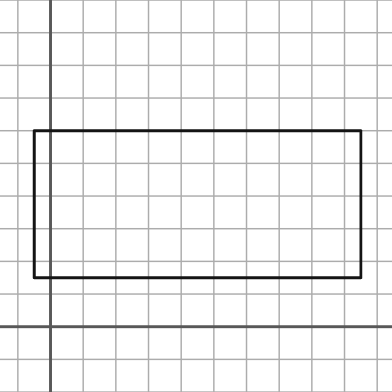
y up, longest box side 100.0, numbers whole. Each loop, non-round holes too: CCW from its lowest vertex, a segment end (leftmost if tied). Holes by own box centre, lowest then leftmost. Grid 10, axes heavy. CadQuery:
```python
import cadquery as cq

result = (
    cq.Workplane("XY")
    .moveTo(-5.0, 15.0)
    .lineTo(95.0, 15.0)
    .lineTo(95.0, 60.0)
    .lineTo(-5.0, 60.0)
    .close()
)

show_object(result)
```